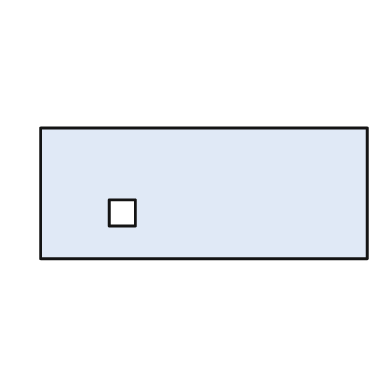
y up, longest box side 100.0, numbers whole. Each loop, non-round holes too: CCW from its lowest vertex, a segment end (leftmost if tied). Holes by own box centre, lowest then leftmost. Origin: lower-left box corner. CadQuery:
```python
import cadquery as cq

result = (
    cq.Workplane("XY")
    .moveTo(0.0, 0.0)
    .lineTo(100.0, 0.0)
    .lineTo(100.0, 40.0)
    .lineTo(0.0, 40.0)
    .close()
    .moveTo(21.0, 10.0)
    .lineTo(29.0, 10.0)
    .lineTo(29.0, 18.0)
    .lineTo(21.0, 18.0)
    .close()
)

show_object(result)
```